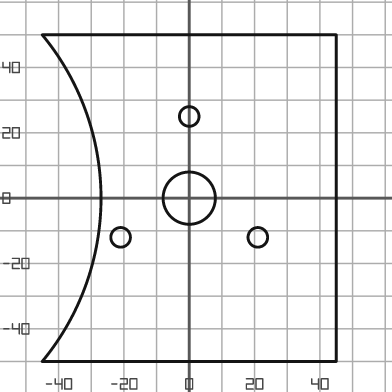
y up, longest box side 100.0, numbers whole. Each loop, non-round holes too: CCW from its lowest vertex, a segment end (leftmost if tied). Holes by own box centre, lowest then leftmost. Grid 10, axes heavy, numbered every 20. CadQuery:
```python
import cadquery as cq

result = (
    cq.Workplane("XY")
    .moveTo(-45.0, -50.0)
    .lineTo(45.0, -50.0)
    .lineTo(45.0, 50.0)
    .lineTo(-45.0, 50.0)
    .threePointArc((-27.0, 0.0), (-45.0, -50.0))
    .close()
    .moveTo(-21.0, -12.0)
    .circle(3.0)
    .moveTo(21.0, -12.0)
    .circle(3.0)
    .moveTo(0.0, 0.0)
    .circle(8.0)
    .moveTo(0.0, 25.0)
    .circle(3.0)
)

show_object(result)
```